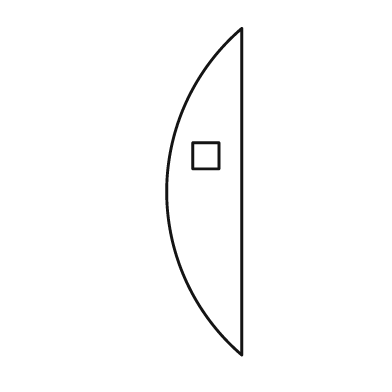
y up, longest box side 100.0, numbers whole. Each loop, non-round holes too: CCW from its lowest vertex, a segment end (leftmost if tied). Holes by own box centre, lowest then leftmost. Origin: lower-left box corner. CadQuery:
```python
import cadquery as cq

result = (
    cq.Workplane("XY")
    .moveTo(23.0, 0.0)
    .lineTo(23.0, 100.0)
    .threePointArc((0.0, 50.0), (23.0, 0.0))
    .close()
    .moveTo(8.0, 57.0)
    .lineTo(16.0, 57.0)
    .lineTo(16.0, 65.0)
    .lineTo(8.0, 65.0)
    .close()
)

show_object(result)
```